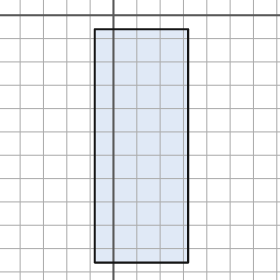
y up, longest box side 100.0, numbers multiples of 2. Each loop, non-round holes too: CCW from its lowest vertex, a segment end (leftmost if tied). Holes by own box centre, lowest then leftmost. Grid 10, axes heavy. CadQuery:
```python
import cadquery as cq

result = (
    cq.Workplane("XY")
    .moveTo(-8.0, -106.0)
    .lineTo(32.0, -106.0)
    .lineTo(32.0, -6.0)
    .lineTo(-8.0, -6.0)
    .close()
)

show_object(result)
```